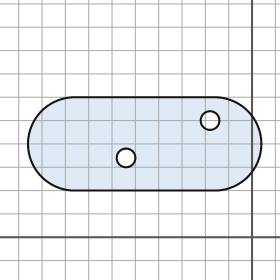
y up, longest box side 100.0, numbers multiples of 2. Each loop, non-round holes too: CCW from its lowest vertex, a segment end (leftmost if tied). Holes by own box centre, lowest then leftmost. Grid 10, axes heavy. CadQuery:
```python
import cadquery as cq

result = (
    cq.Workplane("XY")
    .moveTo(-76.0, 20.0)
    .lineTo(-16.0, 20.0)
    .threePointArc((4.0, 40.0), (-16.0, 60.0))
    .lineTo(-76.0, 60.0)
    .threePointArc((-96.0, 40.0), (-76.0, 20.0))
    .close()
    .moveTo(-54.0, 34.0)
    .circle(4.0)
    .moveTo(-18.0, 50.0)
    .circle(4.0)
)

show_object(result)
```